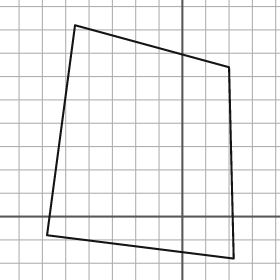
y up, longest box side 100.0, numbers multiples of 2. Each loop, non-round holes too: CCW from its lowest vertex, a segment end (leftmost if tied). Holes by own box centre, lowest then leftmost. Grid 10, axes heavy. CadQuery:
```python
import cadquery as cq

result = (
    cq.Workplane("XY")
    .moveTo(22.0, -18.0)
    .lineTo(20.0, 64.0)
    .lineTo(-46.0, 82.0)
    .lineTo(-58.0, -8.0)
    .close()
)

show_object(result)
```